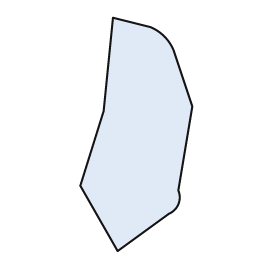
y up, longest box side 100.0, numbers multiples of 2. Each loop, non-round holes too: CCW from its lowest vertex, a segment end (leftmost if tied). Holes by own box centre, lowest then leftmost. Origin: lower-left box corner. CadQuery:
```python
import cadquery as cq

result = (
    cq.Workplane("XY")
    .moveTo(16.0, 0.0)
    .lineTo(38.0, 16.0)
    .threePointArc((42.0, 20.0), (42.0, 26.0))
    .lineTo(48.0, 62.0)
    .lineTo(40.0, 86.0)
    .threePointArc((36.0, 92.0), (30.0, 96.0))
    .lineTo(14.0, 100.0)
    .lineTo(10.0, 60.0)
    .lineTo(0.0, 28.0)
    .close()
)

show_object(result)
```